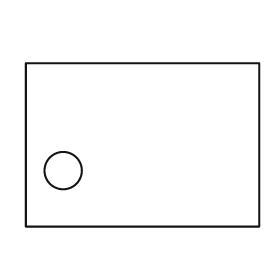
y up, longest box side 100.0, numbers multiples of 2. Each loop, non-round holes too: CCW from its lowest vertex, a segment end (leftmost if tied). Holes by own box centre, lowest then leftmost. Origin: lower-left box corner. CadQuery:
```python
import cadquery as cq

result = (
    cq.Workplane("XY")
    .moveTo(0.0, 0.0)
    .lineTo(100.0, 0.0)
    .lineTo(100.0, 70.0)
    .lineTo(0.0, 70.0)
    .close()
    .moveTo(16.0, 24.0)
    .circle(8.0)
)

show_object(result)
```